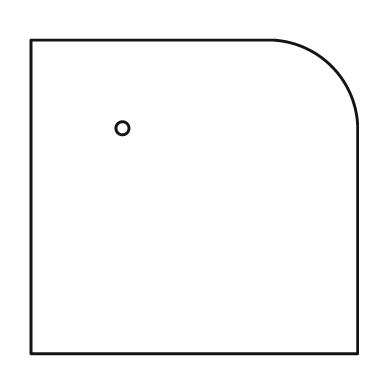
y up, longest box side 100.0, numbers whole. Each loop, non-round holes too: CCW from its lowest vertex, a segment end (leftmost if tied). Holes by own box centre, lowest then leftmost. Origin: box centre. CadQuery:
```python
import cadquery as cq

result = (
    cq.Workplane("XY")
    .moveTo(-50.0, -48.0)
    .lineTo(50.0, -48.0)
    .lineTo(50.0, 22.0)
    .threePointArc((42.0, 40.0), (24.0, 48.0))
    .lineTo(-50.0, 48.0)
    .close()
    .moveTo(-22.0, 21.0)
    .circle(2.0)
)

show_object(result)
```